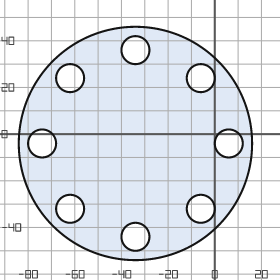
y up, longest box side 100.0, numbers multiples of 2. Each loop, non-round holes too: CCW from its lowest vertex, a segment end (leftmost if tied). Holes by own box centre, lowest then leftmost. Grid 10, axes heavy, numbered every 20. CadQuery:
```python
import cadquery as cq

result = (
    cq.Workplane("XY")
    .moveTo(-34.0, -4.0)
    .circle(50.0)
    .moveTo(-34.0, -44.0)
    .circle(6.0)
    .moveTo(-62.0, -32.0)
    .circle(6.0)
    .moveTo(-6.0, -32.0)
    .circle(6.0)
    .moveTo(-74.0, -4.0)
    .circle(6.0)
    .moveTo(6.0, -4.0)
    .circle(6.0)
    .moveTo(-62.0, 24.0)
    .circle(6.0)
    .moveTo(-6.0, 24.0)
    .circle(6.0)
    .moveTo(-34.0, 36.0)
    .circle(6.0)
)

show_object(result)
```